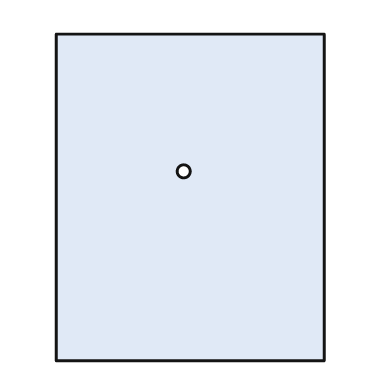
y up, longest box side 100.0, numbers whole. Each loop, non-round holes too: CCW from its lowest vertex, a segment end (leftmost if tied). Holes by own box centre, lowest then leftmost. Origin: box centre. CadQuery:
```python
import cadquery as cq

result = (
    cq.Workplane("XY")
    .moveTo(-41.0, -50.0)
    .lineTo(41.0, -50.0)
    .lineTo(41.0, 50.0)
    .lineTo(-41.0, 50.0)
    .close()
    .moveTo(-2.0, 8.0)
    .circle(2.0)
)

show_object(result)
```